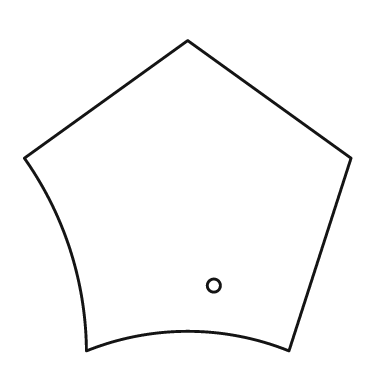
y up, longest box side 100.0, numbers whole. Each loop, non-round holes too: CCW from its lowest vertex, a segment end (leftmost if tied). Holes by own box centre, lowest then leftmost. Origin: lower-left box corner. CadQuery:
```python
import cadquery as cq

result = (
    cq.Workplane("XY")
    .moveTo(19.0, 0.0)
    .threePointArc((50.0, 6.0), (81.0, 0.0))
    .lineTo(100.0, 59.0)
    .lineTo(50.0, 95.0)
    .lineTo(0.0, 59.0)
    .threePointArc((14.0, 31.0), (19.0, 0.0))
    .close()
    .moveTo(58.0, 20.0)
    .circle(2.0)
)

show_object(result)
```